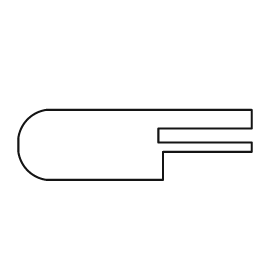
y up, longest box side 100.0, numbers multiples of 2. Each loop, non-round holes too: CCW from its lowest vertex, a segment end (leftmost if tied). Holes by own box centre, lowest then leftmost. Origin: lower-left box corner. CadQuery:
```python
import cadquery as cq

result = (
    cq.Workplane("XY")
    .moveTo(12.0, 0.0)
    .lineTo(62.0, 0.0)
    .lineTo(62.0, 12.0)
    .lineTo(100.0, 12.0)
    .lineTo(100.0, 16.0)
    .lineTo(60.0, 16.0)
    .lineTo(60.0, 22.0)
    .lineTo(100.0, 22.0)
    .lineTo(100.0, 30.0)
    .lineTo(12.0, 30.0)
    .threePointArc((4.0, 26.0), (0.0, 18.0))
    .lineTo(0.0, 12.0)
    .threePointArc((4.0, 4.0), (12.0, 0.0))
    .close()
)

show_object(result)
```